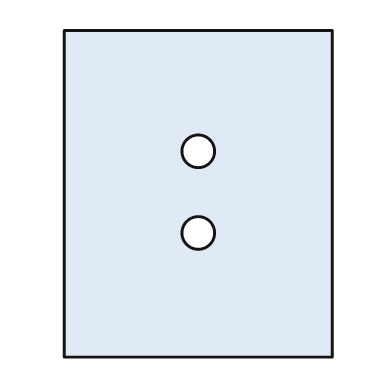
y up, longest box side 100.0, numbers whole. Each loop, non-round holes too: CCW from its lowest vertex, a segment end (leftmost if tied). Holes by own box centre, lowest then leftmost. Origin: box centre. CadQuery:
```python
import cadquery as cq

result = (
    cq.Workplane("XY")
    .moveTo(-41.0, -50.0)
    .lineTo(41.0, -50.0)
    .lineTo(41.0, 50.0)
    .lineTo(-41.0, 50.0)
    .close()
    .moveTo(0.0, -12.0)
    .circle(5.0)
    .moveTo(0.0, 13.0)
    .circle(5.0)
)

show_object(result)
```